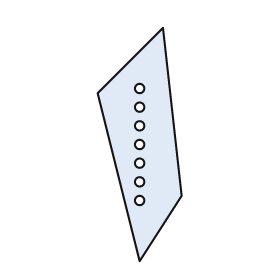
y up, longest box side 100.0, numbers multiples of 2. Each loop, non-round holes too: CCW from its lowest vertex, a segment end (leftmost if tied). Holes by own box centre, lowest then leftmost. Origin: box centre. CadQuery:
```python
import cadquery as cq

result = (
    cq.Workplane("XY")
    .moveTo(0.0, -50.0)
    .lineTo(18.0, -22.0)
    .lineTo(10.0, 50.0)
    .lineTo(-18.0, 22.0)
    .close()
    .moveTo(0.0, -24.0)
    .circle(2.0)
    .moveTo(0.0, -16.0)
    .circle(2.0)
    .moveTo(0.0, -8.0)
    .circle(2.0)
    .moveTo(0.0, 0.0)
    .circle(2.0)
    .moveTo(0.0, 8.0)
    .circle(2.0)
    .moveTo(0.0, 16.0)
    .circle(2.0)
    .moveTo(0.0, 24.0)
    .circle(2.0)
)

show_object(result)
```